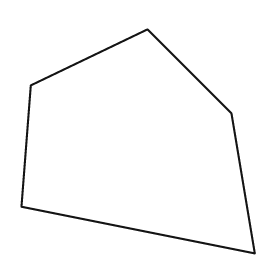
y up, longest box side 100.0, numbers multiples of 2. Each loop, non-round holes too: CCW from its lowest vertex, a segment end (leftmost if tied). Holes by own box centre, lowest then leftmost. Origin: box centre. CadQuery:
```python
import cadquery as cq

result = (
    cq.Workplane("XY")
    .moveTo(50.0, -48.0)
    .lineTo(40.0, 12.0)
    .lineTo(4.0, 48.0)
    .lineTo(-46.0, 24.0)
    .lineTo(-50.0, -28.0)
    .close()
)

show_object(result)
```